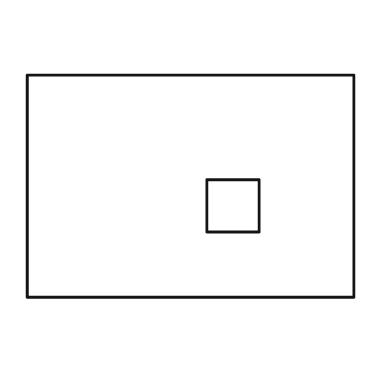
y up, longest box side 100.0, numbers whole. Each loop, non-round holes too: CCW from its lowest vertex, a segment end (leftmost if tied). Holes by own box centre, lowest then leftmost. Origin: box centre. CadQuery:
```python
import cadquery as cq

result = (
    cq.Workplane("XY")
    .moveTo(-50.0, -34.0)
    .lineTo(50.0, -34.0)
    .lineTo(50.0, 34.0)
    .lineTo(-50.0, 34.0)
    .close()
    .moveTo(5.0, -14.0)
    .lineTo(21.0, -14.0)
    .lineTo(21.0, 2.0)
    .lineTo(5.0, 2.0)
    .close()
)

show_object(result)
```